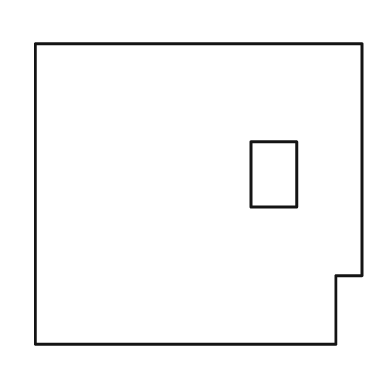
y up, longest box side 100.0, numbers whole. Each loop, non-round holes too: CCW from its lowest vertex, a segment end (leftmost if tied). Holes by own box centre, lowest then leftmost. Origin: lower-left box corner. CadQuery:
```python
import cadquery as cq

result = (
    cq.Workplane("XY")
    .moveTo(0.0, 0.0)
    .lineTo(92.0, 0.0)
    .lineTo(92.0, 21.0)
    .lineTo(100.0, 21.0)
    .lineTo(100.0, 92.0)
    .lineTo(0.0, 92.0)
    .close()
    .moveTo(66.0, 42.0)
    .lineTo(80.0, 42.0)
    .lineTo(80.0, 62.0)
    .lineTo(66.0, 62.0)
    .close()
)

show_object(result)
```